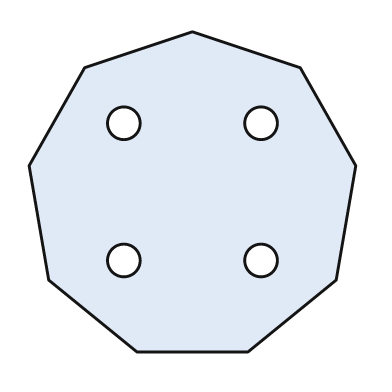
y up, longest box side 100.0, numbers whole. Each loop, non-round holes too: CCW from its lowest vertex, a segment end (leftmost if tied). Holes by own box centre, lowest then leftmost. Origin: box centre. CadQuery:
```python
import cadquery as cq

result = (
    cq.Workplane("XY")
    .moveTo(-17.0, -49.0)
    .lineTo(17.0, -49.0)
    .lineTo(44.0, -27.0)
    .lineTo(50.0, 8.0)
    .lineTo(33.0, 38.0)
    .lineTo(0.0, 49.0)
    .lineTo(-33.0, 38.0)
    .lineTo(-50.0, 8.0)
    .lineTo(-44.0, -27.0)
    .close()
    .moveTo(-21.0, -21.0)
    .circle(5.0)
    .moveTo(21.0, -21.0)
    .circle(5.0)
    .moveTo(-21.0, 21.0)
    .circle(5.0)
    .moveTo(21.0, 21.0)
    .circle(5.0)
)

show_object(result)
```